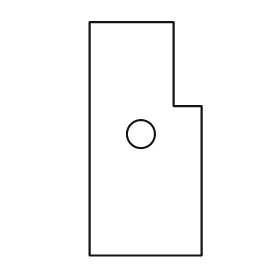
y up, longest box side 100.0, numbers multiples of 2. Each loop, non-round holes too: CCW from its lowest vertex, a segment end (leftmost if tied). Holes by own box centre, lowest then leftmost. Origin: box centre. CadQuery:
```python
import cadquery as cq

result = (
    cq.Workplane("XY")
    .moveTo(-24.0, -50.0)
    .lineTo(24.0, -50.0)
    .lineTo(24.0, 14.0)
    .lineTo(12.0, 14.0)
    .lineTo(12.0, 50.0)
    .lineTo(-24.0, 50.0)
    .close()
    .moveTo(-2.0, 2.0)
    .circle(6.0)
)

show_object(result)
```